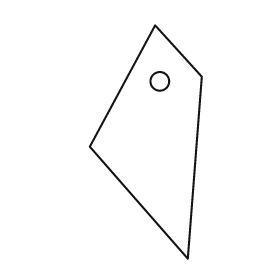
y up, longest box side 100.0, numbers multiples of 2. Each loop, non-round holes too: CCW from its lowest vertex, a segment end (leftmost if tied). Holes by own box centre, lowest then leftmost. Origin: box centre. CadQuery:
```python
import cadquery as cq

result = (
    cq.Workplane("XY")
    .moveTo(18.0, -50.0)
    .lineTo(24.0, 28.0)
    .lineTo(4.0, 50.0)
    .lineTo(-24.0, -2.0)
    .close()
    .moveTo(6.0, 26.0)
    .circle(4.0)
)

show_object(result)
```